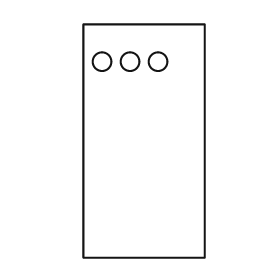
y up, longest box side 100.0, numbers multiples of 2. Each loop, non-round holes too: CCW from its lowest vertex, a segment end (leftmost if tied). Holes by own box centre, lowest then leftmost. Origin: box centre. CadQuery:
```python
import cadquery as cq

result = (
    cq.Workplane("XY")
    .moveTo(-26.0, -50.0)
    .lineTo(26.0, -50.0)
    .lineTo(26.0, 50.0)
    .lineTo(-26.0, 50.0)
    .close()
    .moveTo(-18.0, 34.0)
    .circle(4.0)
    .moveTo(-6.0, 34.0)
    .circle(4.0)
    .moveTo(6.0, 34.0)
    .circle(4.0)
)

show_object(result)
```